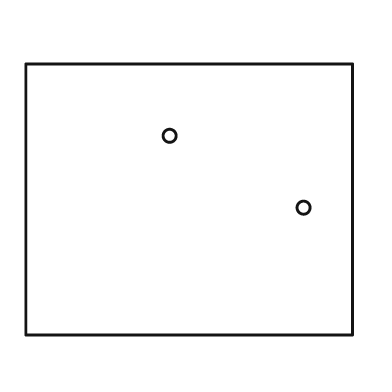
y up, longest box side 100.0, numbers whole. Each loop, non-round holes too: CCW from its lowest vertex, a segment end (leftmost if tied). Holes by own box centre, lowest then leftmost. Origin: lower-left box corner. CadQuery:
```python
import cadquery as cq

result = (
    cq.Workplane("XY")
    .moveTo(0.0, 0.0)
    .lineTo(100.0, 0.0)
    .lineTo(100.0, 83.0)
    .lineTo(0.0, 83.0)
    .close()
    .moveTo(85.0, 39.0)
    .circle(2.0)
    .moveTo(44.0, 61.0)
    .circle(2.0)
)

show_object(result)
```